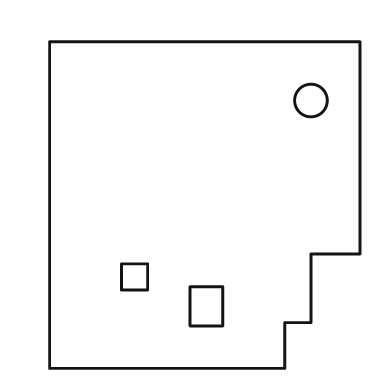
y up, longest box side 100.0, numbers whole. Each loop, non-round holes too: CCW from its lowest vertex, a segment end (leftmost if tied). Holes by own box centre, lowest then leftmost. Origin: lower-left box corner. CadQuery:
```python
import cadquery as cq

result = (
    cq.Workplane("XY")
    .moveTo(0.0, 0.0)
    .lineTo(72.0, 0.0)
    .lineTo(72.0, 14.0)
    .lineTo(80.0, 14.0)
    .lineTo(80.0, 35.0)
    .lineTo(95.0, 35.0)
    .lineTo(95.0, 100.0)
    .lineTo(0.0, 100.0)
    .close()
    .moveTo(43.0, 13.0)
    .lineTo(53.0, 13.0)
    .lineTo(53.0, 25.0)
    .lineTo(43.0, 25.0)
    .close()
    .moveTo(22.0, 24.0)
    .lineTo(30.0, 24.0)
    .lineTo(30.0, 32.0)
    .lineTo(22.0, 32.0)
    .close()
    .moveTo(80.0, 82.0)
    .circle(5.0)
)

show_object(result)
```